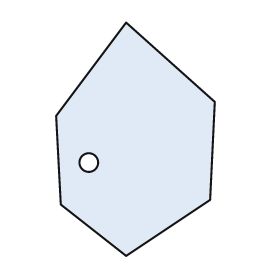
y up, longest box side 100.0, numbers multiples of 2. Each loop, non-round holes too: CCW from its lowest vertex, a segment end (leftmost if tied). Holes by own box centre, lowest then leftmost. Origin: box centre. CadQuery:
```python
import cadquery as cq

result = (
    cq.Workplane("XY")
    .moveTo(-4.0, -50.0)
    .lineTo(32.0, -26.0)
    .lineTo(34.0, 16.0)
    .lineTo(-4.0, 50.0)
    .lineTo(-34.0, 10.0)
    .lineTo(-32.0, -28.0)
    .close()
    .moveTo(-20.0, -10.0)
    .circle(4.0)
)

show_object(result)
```